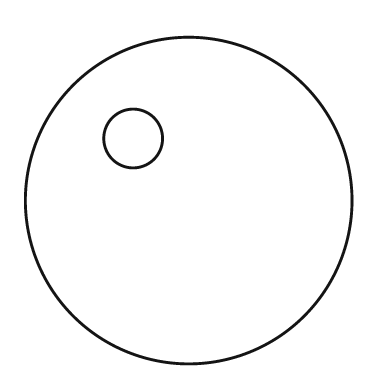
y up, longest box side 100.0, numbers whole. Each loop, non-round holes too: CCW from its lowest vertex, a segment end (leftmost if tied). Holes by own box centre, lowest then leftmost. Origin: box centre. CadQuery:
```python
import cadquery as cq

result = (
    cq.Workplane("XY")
    .moveTo(0.0, 0.0)
    .circle(50.0)
    .moveTo(-17.0, 19.0)
    .circle(9.0)
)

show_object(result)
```